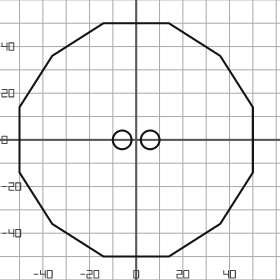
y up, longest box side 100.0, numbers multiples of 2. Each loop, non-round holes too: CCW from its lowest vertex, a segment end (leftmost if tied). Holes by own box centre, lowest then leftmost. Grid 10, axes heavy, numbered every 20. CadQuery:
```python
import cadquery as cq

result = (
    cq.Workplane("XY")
    .moveTo(-14.0, -50.0)
    .lineTo(14.0, -50.0)
    .lineTo(36.0, -36.0)
    .lineTo(50.0, -14.0)
    .lineTo(50.0, 14.0)
    .lineTo(36.0, 36.0)
    .lineTo(14.0, 50.0)
    .lineTo(-14.0, 50.0)
    .lineTo(-36.0, 36.0)
    .lineTo(-50.0, 14.0)
    .lineTo(-50.0, -14.0)
    .lineTo(-36.0, -36.0)
    .close()
    .moveTo(-6.0, 0.0)
    .circle(4.0)
    .moveTo(6.0, 0.0)
    .circle(4.0)
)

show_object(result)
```